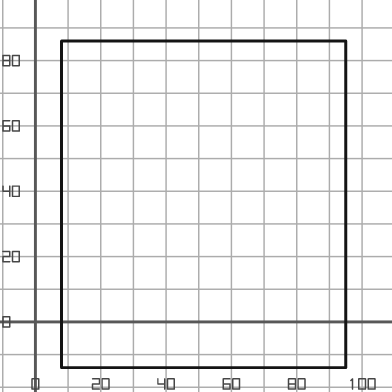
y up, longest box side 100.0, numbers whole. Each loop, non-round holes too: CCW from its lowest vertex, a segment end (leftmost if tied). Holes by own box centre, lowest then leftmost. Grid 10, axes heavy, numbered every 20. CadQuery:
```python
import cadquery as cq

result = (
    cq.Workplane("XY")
    .moveTo(8.0, -14.0)
    .lineTo(95.0, -14.0)
    .lineTo(95.0, 86.0)
    .lineTo(8.0, 86.0)
    .close()
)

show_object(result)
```